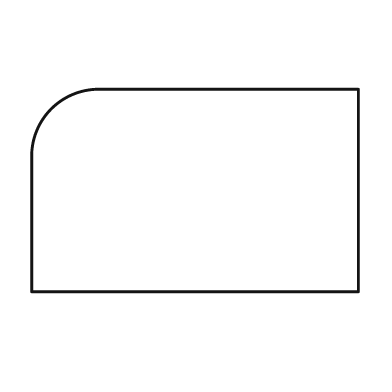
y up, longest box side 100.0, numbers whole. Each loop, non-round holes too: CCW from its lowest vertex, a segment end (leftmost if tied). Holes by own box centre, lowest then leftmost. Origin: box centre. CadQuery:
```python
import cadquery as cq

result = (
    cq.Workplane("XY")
    .moveTo(-50.0, -31.0)
    .lineTo(50.0, -31.0)
    .lineTo(50.0, 31.0)
    .lineTo(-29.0, 31.0)
    .threePointArc((-44.0, 25.0), (-50.0, 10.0))
    .close()
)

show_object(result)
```